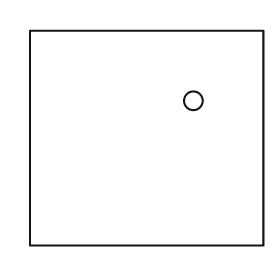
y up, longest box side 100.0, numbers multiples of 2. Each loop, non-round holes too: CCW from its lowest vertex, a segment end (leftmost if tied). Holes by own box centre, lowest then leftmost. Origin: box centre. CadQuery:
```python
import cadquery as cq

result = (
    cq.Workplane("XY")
    .moveTo(-50.0, -46.0)
    .lineTo(50.0, -46.0)
    .lineTo(50.0, 46.0)
    .lineTo(-50.0, 46.0)
    .close()
    .moveTo(20.0, 16.0)
    .circle(4.0)
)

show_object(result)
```